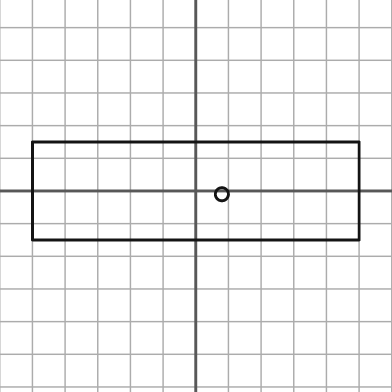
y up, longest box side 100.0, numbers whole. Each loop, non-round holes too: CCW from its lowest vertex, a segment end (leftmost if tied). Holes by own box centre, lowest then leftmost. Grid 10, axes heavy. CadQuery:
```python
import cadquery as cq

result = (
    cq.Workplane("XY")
    .moveTo(-50.0, -15.0)
    .lineTo(50.0, -15.0)
    .lineTo(50.0, 15.0)
    .lineTo(-50.0, 15.0)
    .close()
    .moveTo(8.0, -1.0)
    .circle(2.0)
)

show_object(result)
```